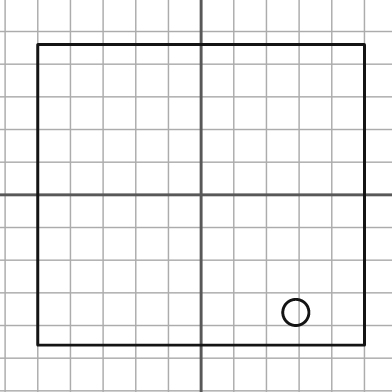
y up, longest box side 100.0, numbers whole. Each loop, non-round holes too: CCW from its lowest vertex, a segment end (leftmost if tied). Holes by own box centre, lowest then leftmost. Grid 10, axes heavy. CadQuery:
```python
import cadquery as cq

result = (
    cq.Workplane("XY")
    .moveTo(-50.0, -46.0)
    .lineTo(50.0, -46.0)
    .lineTo(50.0, 46.0)
    .lineTo(-50.0, 46.0)
    .close()
    .moveTo(29.0, -36.0)
    .circle(4.0)
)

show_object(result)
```